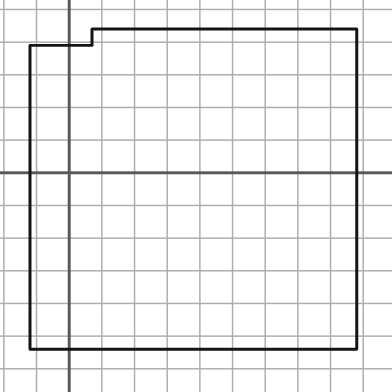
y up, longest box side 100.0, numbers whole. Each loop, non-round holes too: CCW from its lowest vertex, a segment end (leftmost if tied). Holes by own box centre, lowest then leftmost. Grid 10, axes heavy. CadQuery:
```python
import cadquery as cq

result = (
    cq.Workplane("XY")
    .moveTo(-12.0, -54.0)
    .lineTo(88.0, -54.0)
    .lineTo(88.0, 44.0)
    .lineTo(7.0, 44.0)
    .lineTo(7.0, 39.0)
    .lineTo(-12.0, 39.0)
    .close()
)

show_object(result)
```